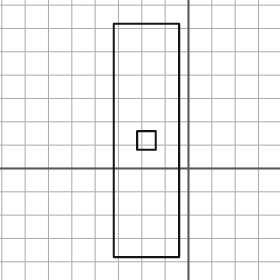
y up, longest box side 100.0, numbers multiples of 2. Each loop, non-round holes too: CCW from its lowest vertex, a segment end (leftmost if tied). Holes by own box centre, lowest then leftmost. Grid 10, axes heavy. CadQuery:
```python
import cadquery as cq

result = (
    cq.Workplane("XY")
    .moveTo(-32.0, -38.0)
    .lineTo(-4.0, -38.0)
    .lineTo(-4.0, 62.0)
    .lineTo(-32.0, 62.0)
    .close()
    .moveTo(-22.0, 8.0)
    .lineTo(-14.0, 8.0)
    .lineTo(-14.0, 16.0)
    .lineTo(-22.0, 16.0)
    .close()
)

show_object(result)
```